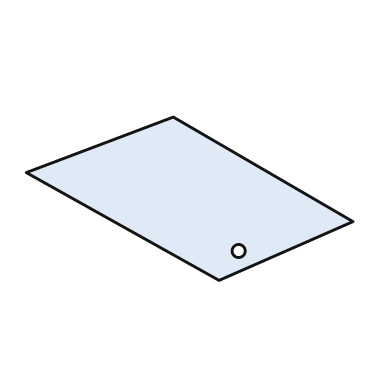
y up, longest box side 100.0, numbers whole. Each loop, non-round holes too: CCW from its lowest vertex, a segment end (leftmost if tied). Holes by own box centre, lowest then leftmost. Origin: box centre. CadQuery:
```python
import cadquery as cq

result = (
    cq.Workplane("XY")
    .moveTo(9.0, -25.0)
    .lineTo(50.0, -7.0)
    .lineTo(-5.0, 25.0)
    .lineTo(-50.0, 8.0)
    .close()
    .moveTo(15.0, -16.0)
    .circle(2.0)
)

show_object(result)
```